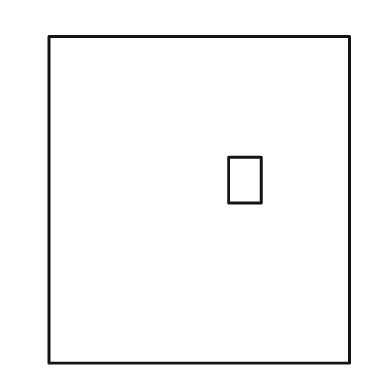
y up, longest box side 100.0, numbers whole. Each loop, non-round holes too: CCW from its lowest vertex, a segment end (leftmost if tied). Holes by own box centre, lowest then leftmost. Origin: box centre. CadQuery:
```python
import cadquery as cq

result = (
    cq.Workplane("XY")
    .moveTo(-46.0, -50.0)
    .lineTo(46.0, -50.0)
    .lineTo(46.0, 50.0)
    .lineTo(-46.0, 50.0)
    .close()
    .moveTo(9.0, -1.0)
    .lineTo(19.0, -1.0)
    .lineTo(19.0, 13.0)
    .lineTo(9.0, 13.0)
    .close()
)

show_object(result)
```